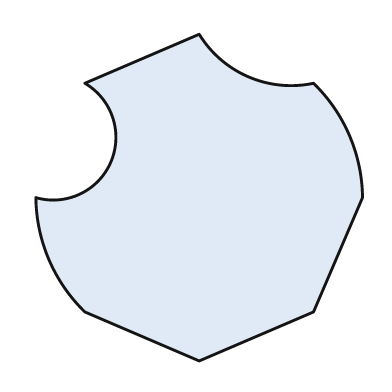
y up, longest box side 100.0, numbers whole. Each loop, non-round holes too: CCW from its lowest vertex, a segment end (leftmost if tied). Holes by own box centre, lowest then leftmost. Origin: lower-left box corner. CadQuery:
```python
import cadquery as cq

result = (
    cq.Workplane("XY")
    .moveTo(50.0, 0.0)
    .lineTo(85.0, 15.0)
    .lineTo(100.0, 50.0)
    .threePointArc((96.0, 69.0), (85.0, 85.0))
    .threePointArc((65.0, 87.0), (50.0, 100.0))
    .lineTo(15.0, 85.0)
    .threePointArc((23.0, 61.0), (0.0, 50.0))
    .threePointArc((4.0, 31.0), (15.0, 15.0))
    .close()
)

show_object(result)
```